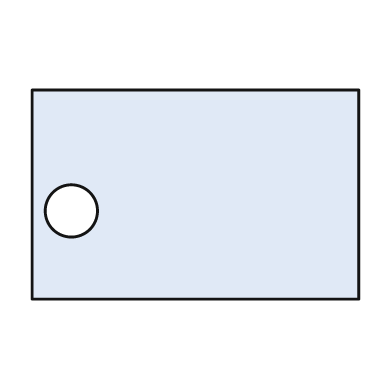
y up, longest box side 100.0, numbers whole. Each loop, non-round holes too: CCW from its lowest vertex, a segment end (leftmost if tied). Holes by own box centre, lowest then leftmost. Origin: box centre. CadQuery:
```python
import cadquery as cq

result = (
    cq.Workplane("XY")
    .moveTo(-50.0, -32.0)
    .lineTo(50.0, -32.0)
    .lineTo(50.0, 32.0)
    .lineTo(-50.0, 32.0)
    .close()
    .moveTo(-38.0, -5.0)
    .circle(8.0)
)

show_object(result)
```